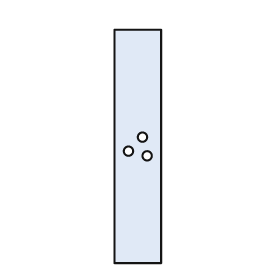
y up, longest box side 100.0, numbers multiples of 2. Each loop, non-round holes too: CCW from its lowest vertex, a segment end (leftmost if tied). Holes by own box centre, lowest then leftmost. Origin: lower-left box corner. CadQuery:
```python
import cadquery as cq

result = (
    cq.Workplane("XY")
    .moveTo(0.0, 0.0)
    .lineTo(20.0, 0.0)
    .lineTo(20.0, 100.0)
    .lineTo(0.0, 100.0)
    .close()
    .moveTo(14.0, 46.0)
    .circle(2.0)
    .moveTo(6.0, 48.0)
    .circle(2.0)
    .moveTo(12.0, 54.0)
    .circle(2.0)
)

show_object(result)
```